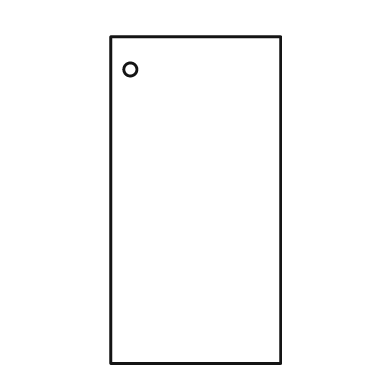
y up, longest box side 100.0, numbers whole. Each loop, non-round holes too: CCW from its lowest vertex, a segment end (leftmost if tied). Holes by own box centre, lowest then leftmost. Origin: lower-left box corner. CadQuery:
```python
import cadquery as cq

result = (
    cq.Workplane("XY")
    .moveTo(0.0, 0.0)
    .lineTo(52.0, 0.0)
    .lineTo(52.0, 100.0)
    .lineTo(0.0, 100.0)
    .close()
    .moveTo(6.0, 90.0)
    .circle(2.0)
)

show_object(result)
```